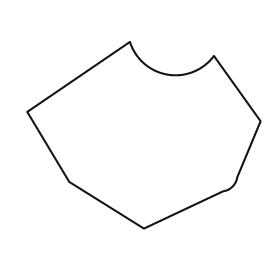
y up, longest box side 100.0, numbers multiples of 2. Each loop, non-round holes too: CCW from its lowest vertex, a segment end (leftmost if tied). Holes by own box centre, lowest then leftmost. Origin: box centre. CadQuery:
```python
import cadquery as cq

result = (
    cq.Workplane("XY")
    .moveTo(0.0, -40.0)
    .lineTo(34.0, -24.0)
    .threePointArc((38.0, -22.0), (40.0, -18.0))
    .lineTo(50.0, 6.0)
    .lineTo(30.0, 34.0)
    .threePointArc((10.0, 26.0), (-6.0, 40.0))
    .lineTo(-50.0, 10.0)
    .lineTo(-32.0, -20.0)
    .close()
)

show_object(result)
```